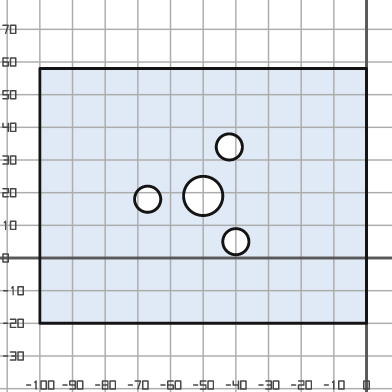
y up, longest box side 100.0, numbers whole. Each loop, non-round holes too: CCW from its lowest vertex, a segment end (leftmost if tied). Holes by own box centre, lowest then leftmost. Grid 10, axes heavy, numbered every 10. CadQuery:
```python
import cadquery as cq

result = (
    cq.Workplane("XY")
    .moveTo(-100.0, -20.0)
    .lineTo(0.0, -20.0)
    .lineTo(0.0, 58.0)
    .lineTo(-100.0, 58.0)
    .close()
    .moveTo(-40.0, 5.0)
    .circle(4.0)
    .moveTo(-67.0, 18.0)
    .circle(4.0)
    .moveTo(-50.0, 19.0)
    .circle(6.0)
    .moveTo(-42.0, 34.0)
    .circle(4.0)
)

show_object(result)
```